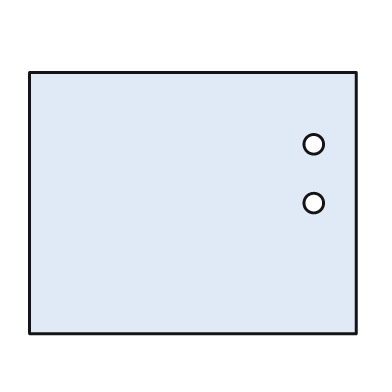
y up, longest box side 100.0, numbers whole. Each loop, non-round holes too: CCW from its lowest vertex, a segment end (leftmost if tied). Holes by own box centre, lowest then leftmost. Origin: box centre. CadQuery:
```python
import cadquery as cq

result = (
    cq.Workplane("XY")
    .moveTo(-50.0, -40.0)
    .lineTo(50.0, -40.0)
    .lineTo(50.0, 40.0)
    .lineTo(-50.0, 40.0)
    .close()
    .moveTo(37.0, 0.0)
    .circle(3.0)
    .moveTo(37.0, 18.0)
    .circle(3.0)
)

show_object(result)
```